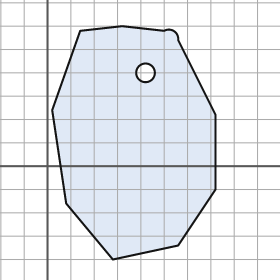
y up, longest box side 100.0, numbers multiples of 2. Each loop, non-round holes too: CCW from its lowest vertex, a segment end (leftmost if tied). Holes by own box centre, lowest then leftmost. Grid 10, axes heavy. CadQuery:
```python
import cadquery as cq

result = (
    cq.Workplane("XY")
    .moveTo(28.0, -40.0)
    .lineTo(56.0, -34.0)
    .lineTo(72.0, -10.0)
    .lineTo(72.0, 22.0)
    .lineTo(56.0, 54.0)
    .threePointArc((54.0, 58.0), (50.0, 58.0))
    .lineTo(32.0, 60.0)
    .lineTo(14.0, 58.0)
    .lineTo(2.0, 24.0)
    .lineTo(8.0, -16.0)
    .close()
    .moveTo(42.0, 40.0)
    .circle(4.0)
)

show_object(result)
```